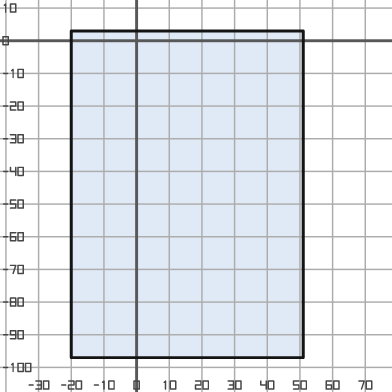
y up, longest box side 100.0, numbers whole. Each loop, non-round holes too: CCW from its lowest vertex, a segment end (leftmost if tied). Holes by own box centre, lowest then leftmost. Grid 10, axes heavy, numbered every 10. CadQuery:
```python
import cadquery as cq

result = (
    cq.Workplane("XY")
    .moveTo(-20.0, -97.0)
    .lineTo(51.0, -97.0)
    .lineTo(51.0, 3.0)
    .lineTo(-20.0, 3.0)
    .close()
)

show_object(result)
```